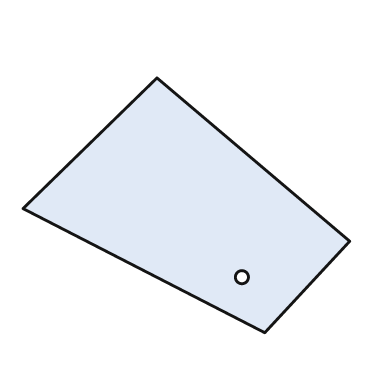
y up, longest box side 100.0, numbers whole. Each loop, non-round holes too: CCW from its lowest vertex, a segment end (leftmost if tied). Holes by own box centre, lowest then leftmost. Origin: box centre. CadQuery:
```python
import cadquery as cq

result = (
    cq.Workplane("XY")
    .moveTo(24.0, -39.0)
    .lineTo(50.0, -11.0)
    .lineTo(-9.0, 39.0)
    .lineTo(-50.0, -1.0)
    .close()
    .moveTo(17.0, -22.0)
    .circle(2.0)
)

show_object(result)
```